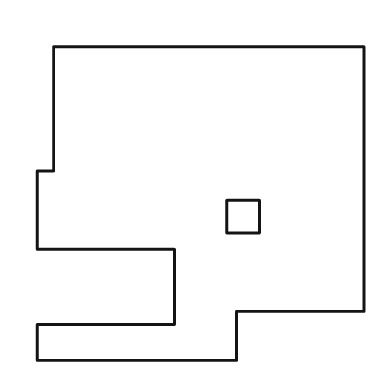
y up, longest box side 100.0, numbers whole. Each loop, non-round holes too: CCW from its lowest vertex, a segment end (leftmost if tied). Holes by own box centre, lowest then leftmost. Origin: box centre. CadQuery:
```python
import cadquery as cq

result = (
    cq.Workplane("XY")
    .moveTo(-50.0, -48.0)
    .lineTo(11.0, -48.0)
    .lineTo(11.0, -33.0)
    .lineTo(50.0, -33.0)
    .lineTo(50.0, 48.0)
    .lineTo(-45.0, 48.0)
    .lineTo(-45.0, 10.0)
    .lineTo(-50.0, 10.0)
    .lineTo(-50.0, -14.0)
    .lineTo(-8.0, -14.0)
    .lineTo(-8.0, -37.0)
    .lineTo(-50.0, -37.0)
    .close()
    .moveTo(8.0, -9.0)
    .lineTo(18.0, -9.0)
    .lineTo(18.0, 1.0)
    .lineTo(8.0, 1.0)
    .close()
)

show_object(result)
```